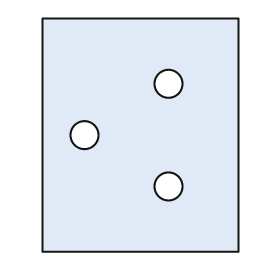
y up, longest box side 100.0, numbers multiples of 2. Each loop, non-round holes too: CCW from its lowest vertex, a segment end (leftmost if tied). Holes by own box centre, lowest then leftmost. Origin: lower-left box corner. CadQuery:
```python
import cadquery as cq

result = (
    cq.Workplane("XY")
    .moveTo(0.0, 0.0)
    .lineTo(84.0, 0.0)
    .lineTo(84.0, 100.0)
    .lineTo(0.0, 100.0)
    .close()
    .moveTo(54.0, 28.0)
    .circle(6.0)
    .moveTo(18.0, 50.0)
    .circle(6.0)
    .moveTo(54.0, 72.0)
    .circle(6.0)
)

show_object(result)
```